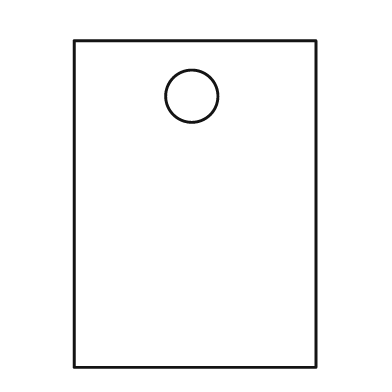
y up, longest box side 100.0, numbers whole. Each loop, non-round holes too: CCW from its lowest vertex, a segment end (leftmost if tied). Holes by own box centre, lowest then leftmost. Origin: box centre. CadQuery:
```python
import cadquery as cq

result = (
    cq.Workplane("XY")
    .moveTo(-37.0, -50.0)
    .lineTo(37.0, -50.0)
    .lineTo(37.0, 50.0)
    .lineTo(-37.0, 50.0)
    .close()
    .moveTo(-1.0, 33.0)
    .circle(8.0)
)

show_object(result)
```